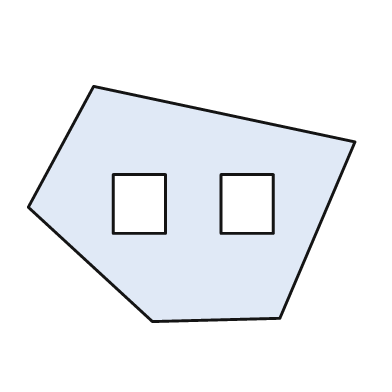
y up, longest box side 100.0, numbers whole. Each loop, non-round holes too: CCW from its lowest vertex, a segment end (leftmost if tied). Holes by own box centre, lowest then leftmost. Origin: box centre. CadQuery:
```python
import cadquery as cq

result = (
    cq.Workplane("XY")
    .moveTo(-12.0, -36.0)
    .lineTo(27.0, -35.0)
    .lineTo(50.0, 19.0)
    .lineTo(-30.0, 36.0)
    .lineTo(-50.0, -1.0)
    .close()
    .moveTo(-24.0, -9.0)
    .lineTo(-8.0, -9.0)
    .lineTo(-8.0, 9.0)
    .lineTo(-24.0, 9.0)
    .close()
    .moveTo(9.0, -9.0)
    .lineTo(25.0, -9.0)
    .lineTo(25.0, 9.0)
    .lineTo(9.0, 9.0)
    .close()
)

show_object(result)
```